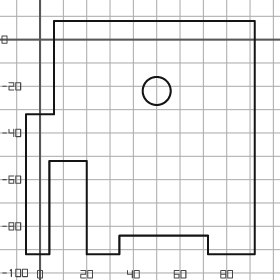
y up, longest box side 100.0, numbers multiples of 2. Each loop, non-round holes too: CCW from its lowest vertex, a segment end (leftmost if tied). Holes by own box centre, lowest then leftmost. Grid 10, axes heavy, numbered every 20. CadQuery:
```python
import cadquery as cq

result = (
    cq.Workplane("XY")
    .moveTo(-6.0, -92.0)
    .lineTo(4.0, -92.0)
    .lineTo(4.0, -52.0)
    .lineTo(20.0, -52.0)
    .lineTo(20.0, -92.0)
    .lineTo(34.0, -92.0)
    .lineTo(34.0, -84.0)
    .lineTo(72.0, -84.0)
    .lineTo(72.0, -92.0)
    .lineTo(92.0, -92.0)
    .lineTo(92.0, 8.0)
    .lineTo(6.0, 8.0)
    .lineTo(6.0, -32.0)
    .lineTo(-6.0, -32.0)
    .close()
    .moveTo(50.0, -22.0)
    .circle(6.0)
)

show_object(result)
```